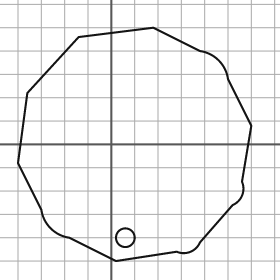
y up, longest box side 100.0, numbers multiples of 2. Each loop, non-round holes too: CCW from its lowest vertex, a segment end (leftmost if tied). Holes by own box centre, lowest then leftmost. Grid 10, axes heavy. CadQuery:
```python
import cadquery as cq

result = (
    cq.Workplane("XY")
    .moveTo(2.0, -50.0)
    .lineTo(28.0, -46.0)
    .threePointArc((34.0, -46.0), (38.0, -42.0))
    .lineTo(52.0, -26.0)
    .threePointArc((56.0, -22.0), (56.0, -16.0))
    .lineTo(60.0, 8.0)
    .lineTo(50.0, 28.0)
    .threePointArc((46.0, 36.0), (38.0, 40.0))
    .lineTo(18.0, 50.0)
    .lineTo(-14.0, 46.0)
    .lineTo(-36.0, 22.0)
    .lineTo(-40.0, -8.0)
    .lineTo(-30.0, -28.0)
    .threePointArc((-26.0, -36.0), (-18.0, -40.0))
    .close()
    .moveTo(6.0, -40.0)
    .circle(4.0)
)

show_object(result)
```